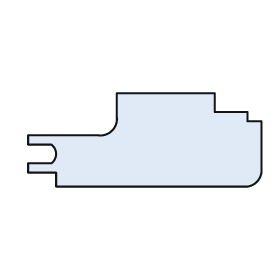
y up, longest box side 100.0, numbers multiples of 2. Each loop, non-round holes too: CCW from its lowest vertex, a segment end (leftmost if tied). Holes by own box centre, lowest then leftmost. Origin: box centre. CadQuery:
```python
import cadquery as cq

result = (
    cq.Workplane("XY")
    .moveTo(-38.0, -20.0)
    .lineTo(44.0, -20.0)
    .threePointArc((48.0, -18.0), (50.0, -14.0))
    .lineTo(50.0, 8.0)
    .lineTo(44.0, 8.0)
    .lineTo(44.0, 12.0)
    .lineTo(30.0, 12.0)
    .lineTo(30.0, 20.0)
    .lineTo(-12.0, 20.0)
    .lineTo(-12.0, 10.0)
    .threePointArc((-14.0, 4.0), (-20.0, 2.0))
    .lineTo(-50.0, 2.0)
    .lineTo(-50.0, -2.0)
    .lineTo(-40.0, -2.0)
    .threePointArc((-38.0, -6.0), (-40.0, -10.0))
    .lineTo(-50.0, -10.0)
    .lineTo(-50.0, -14.0)
    .lineTo(-38.0, -14.0)
    .close()
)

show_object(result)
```